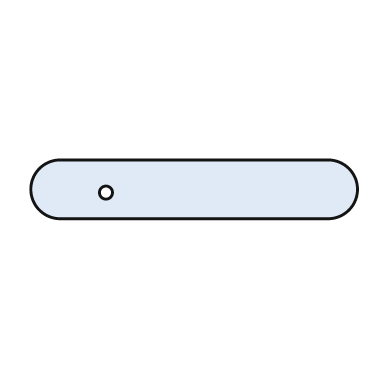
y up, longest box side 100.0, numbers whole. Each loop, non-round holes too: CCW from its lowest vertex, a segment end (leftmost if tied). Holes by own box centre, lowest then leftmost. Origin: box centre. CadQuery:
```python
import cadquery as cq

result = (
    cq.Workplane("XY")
    .moveTo(-41.0, -9.0)
    .lineTo(41.0, -9.0)
    .threePointArc((50.0, 0.0), (41.0, 9.0))
    .lineTo(-41.0, 9.0)
    .threePointArc((-50.0, 0.0), (-41.0, -9.0))
    .close()
    .moveTo(-27.0, -1.0)
    .circle(2.0)
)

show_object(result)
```